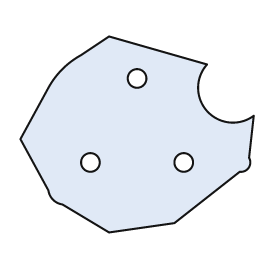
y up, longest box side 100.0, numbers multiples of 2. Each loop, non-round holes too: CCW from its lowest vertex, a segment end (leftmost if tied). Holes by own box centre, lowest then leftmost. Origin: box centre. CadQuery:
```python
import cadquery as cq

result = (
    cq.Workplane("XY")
    .moveTo(-12.0, -42.0)
    .lineTo(16.0, -38.0)
    .lineTo(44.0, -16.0)
    .threePointArc((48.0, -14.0), (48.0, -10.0))
    .lineTo(50.0, 8.0)
    .threePointArc((30.0, 10.0), (30.0, 30.0))
    .lineTo(-12.0, 42.0)
    .lineTo(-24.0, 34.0)
    .threePointArc((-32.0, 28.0), (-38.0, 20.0))
    .lineTo(-50.0, -2.0)
    .lineTo(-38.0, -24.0)
    .threePointArc((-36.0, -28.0), (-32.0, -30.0))
    .close()
    .moveTo(-20.0, -12.0)
    .circle(4.0)
    .moveTo(20.0, -12.0)
    .circle(4.0)
    .moveTo(0.0, 24.0)
    .circle(4.0)
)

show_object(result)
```